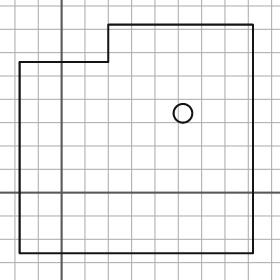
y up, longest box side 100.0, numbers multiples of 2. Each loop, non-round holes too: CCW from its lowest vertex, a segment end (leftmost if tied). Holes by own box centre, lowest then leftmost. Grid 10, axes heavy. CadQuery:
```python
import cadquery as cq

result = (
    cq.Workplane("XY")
    .moveTo(-18.0, -26.0)
    .lineTo(82.0, -26.0)
    .lineTo(82.0, 72.0)
    .lineTo(20.0, 72.0)
    .lineTo(20.0, 56.0)
    .lineTo(-18.0, 56.0)
    .close()
    .moveTo(52.0, 34.0)
    .circle(4.0)
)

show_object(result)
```